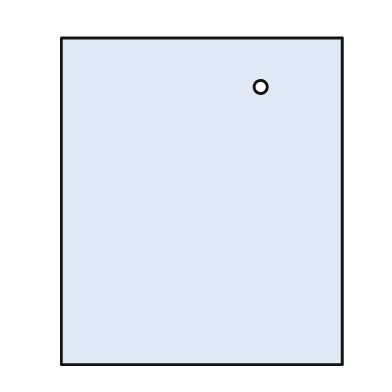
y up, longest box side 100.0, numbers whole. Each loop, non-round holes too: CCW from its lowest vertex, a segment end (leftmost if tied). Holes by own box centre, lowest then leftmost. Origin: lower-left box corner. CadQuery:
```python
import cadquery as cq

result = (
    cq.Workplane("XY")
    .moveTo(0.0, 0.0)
    .lineTo(86.0, 0.0)
    .lineTo(86.0, 100.0)
    .lineTo(0.0, 100.0)
    .close()
    .moveTo(61.0, 85.0)
    .circle(2.0)
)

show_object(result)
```